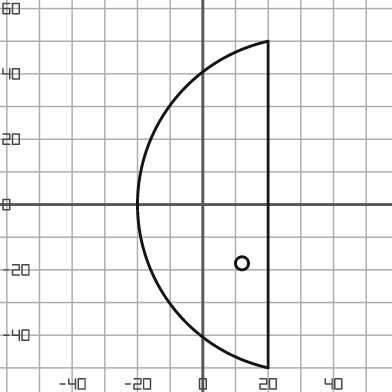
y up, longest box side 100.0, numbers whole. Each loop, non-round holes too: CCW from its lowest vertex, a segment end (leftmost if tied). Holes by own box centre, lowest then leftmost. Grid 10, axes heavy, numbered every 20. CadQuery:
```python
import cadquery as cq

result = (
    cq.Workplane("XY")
    .moveTo(20.0, -50.0)
    .lineTo(20.0, 50.0)
    .threePointArc((-20.0, 0.0), (20.0, -50.0))
    .close()
    .moveTo(12.0, -18.0)
    .circle(2.0)
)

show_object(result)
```